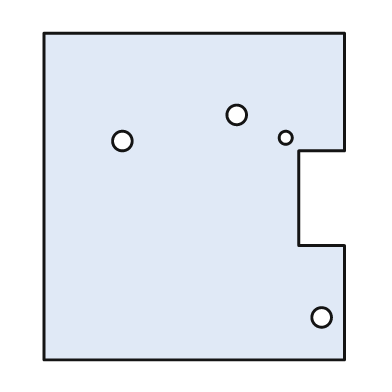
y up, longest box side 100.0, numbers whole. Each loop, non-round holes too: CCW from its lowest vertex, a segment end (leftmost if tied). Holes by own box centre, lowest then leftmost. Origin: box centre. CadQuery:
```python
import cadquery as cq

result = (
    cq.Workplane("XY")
    .moveTo(-46.0, -50.0)
    .lineTo(46.0, -50.0)
    .lineTo(46.0, -15.0)
    .lineTo(32.0, -15.0)
    .lineTo(32.0, 14.0)
    .lineTo(46.0, 14.0)
    .lineTo(46.0, 50.0)
    .lineTo(-46.0, 50.0)
    .close()
    .moveTo(39.0, -37.0)
    .circle(3.0)
    .moveTo(-22.0, 17.0)
    .circle(3.0)
    .moveTo(28.0, 18.0)
    .circle(2.0)
    .moveTo(13.0, 25.0)
    .circle(3.0)
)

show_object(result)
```